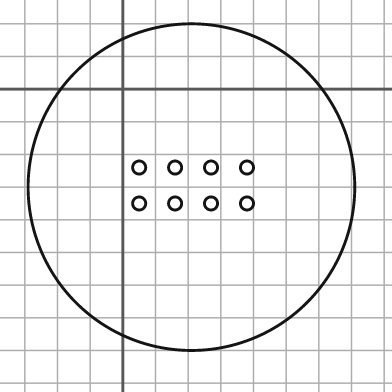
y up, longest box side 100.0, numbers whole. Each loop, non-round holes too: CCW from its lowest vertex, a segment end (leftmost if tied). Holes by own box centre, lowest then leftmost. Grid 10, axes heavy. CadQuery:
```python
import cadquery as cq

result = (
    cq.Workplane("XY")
    .moveTo(21.0, -30.0)
    .circle(50.0)
    .moveTo(5.0, -35.0)
    .circle(2.0)
    .moveTo(16.0, -35.0)
    .circle(2.0)
    .moveTo(27.0, -35.0)
    .circle(2.0)
    .moveTo(38.0, -35.0)
    .circle(2.0)
    .moveTo(5.0, -24.0)
    .circle(2.0)
    .moveTo(16.0, -24.0)
    .circle(2.0)
    .moveTo(27.0, -24.0)
    .circle(2.0)
    .moveTo(38.0, -24.0)
    .circle(2.0)
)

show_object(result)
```